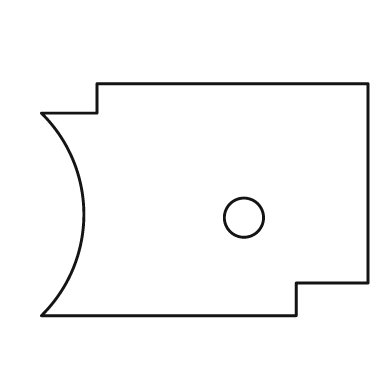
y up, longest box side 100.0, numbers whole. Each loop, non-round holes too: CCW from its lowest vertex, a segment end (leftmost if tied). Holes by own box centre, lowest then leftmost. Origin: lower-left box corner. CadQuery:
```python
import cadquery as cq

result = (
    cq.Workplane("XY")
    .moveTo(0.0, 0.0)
    .lineTo(78.0, 0.0)
    .lineTo(78.0, 10.0)
    .lineTo(100.0, 10.0)
    .lineTo(100.0, 71.0)
    .lineTo(17.0, 71.0)
    .lineTo(17.0, 62.0)
    .lineTo(0.0, 62.0)
    .threePointArc((13.0, 31.0), (0.0, 0.0))
    .close()
    .moveTo(62.0, 30.0)
    .circle(6.0)
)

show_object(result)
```